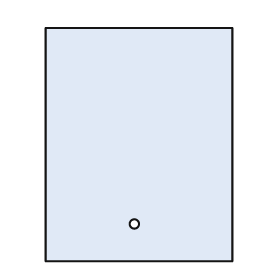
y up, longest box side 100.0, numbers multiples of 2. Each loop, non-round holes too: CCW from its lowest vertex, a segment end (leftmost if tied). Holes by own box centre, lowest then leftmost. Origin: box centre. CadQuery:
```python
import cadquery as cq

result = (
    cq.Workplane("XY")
    .moveTo(-40.0, -50.0)
    .lineTo(40.0, -50.0)
    .lineTo(40.0, 50.0)
    .lineTo(-40.0, 50.0)
    .close()
    .moveTo(-2.0, -34.0)
    .circle(2.0)
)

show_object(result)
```